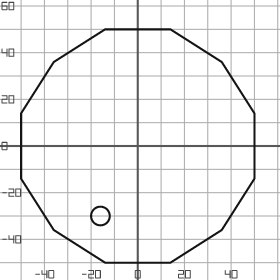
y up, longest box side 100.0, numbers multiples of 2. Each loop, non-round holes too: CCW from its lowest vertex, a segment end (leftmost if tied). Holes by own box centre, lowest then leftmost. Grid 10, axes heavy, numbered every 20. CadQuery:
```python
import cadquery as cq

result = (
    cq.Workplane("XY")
    .moveTo(-14.0, -50.0)
    .lineTo(14.0, -50.0)
    .lineTo(36.0, -36.0)
    .lineTo(50.0, -14.0)
    .lineTo(50.0, 14.0)
    .lineTo(36.0, 36.0)
    .lineTo(14.0, 50.0)
    .lineTo(-14.0, 50.0)
    .lineTo(-36.0, 36.0)
    .lineTo(-50.0, 14.0)
    .lineTo(-50.0, -14.0)
    .lineTo(-36.0, -36.0)
    .close()
    .moveTo(-16.0, -30.0)
    .circle(4.0)
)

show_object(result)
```